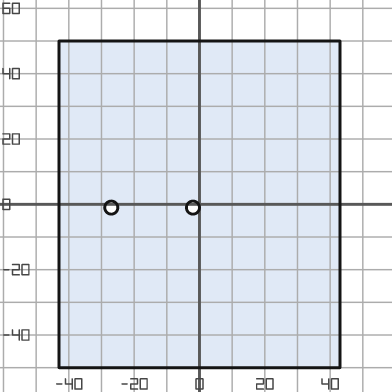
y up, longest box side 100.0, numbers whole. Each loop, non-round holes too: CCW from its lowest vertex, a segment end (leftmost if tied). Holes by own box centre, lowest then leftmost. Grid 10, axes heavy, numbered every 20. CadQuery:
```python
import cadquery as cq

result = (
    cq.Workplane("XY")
    .moveTo(-43.0, -50.0)
    .lineTo(43.0, -50.0)
    .lineTo(43.0, 50.0)
    .lineTo(-43.0, 50.0)
    .close()
    .moveTo(-27.0, -1.0)
    .circle(2.0)
    .moveTo(-2.0, -1.0)
    .circle(2.0)
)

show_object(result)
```